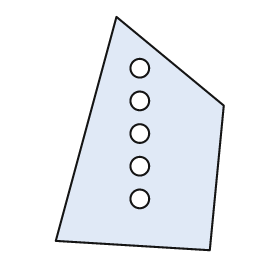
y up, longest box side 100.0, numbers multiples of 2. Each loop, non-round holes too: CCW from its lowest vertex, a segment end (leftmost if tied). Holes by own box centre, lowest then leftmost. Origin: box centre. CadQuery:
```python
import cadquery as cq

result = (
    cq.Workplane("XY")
    .moveTo(30.0, -50.0)
    .lineTo(36.0, 12.0)
    .lineTo(-10.0, 50.0)
    .lineTo(-36.0, -46.0)
    .close()
    .moveTo(0.0, -28.0)
    .circle(4.0)
    .moveTo(0.0, -14.0)
    .circle(4.0)
    .moveTo(0.0, 0.0)
    .circle(4.0)
    .moveTo(0.0, 14.0)
    .circle(4.0)
    .moveTo(0.0, 28.0)
    .circle(4.0)
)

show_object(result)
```